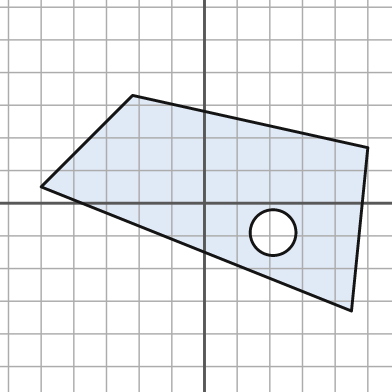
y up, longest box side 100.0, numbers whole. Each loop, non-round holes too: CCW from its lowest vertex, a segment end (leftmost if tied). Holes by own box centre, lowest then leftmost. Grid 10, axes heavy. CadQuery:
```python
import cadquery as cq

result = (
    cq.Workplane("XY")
    .moveTo(45.0, -33.0)
    .lineTo(50.0, 17.0)
    .lineTo(-22.0, 33.0)
    .lineTo(-50.0, 5.0)
    .close()
    .moveTo(21.0, -9.0)
    .circle(7.0)
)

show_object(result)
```